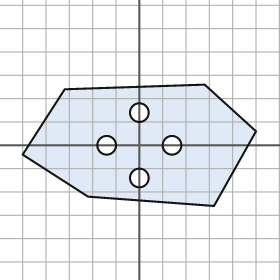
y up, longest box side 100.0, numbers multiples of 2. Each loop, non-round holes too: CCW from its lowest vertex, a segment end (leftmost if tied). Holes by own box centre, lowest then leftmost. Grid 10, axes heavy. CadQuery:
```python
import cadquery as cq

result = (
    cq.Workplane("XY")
    .moveTo(32.0, -26.0)
    .lineTo(50.0, 6.0)
    .lineTo(28.0, 26.0)
    .lineTo(-32.0, 24.0)
    .lineTo(-50.0, -4.0)
    .lineTo(-22.0, -22.0)
    .close()
    .moveTo(0.0, -14.0)
    .circle(4.0)
    .moveTo(-14.0, 0.0)
    .circle(4.0)
    .moveTo(14.0, 0.0)
    .circle(4.0)
    .moveTo(0.0, 14.0)
    .circle(4.0)
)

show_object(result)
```